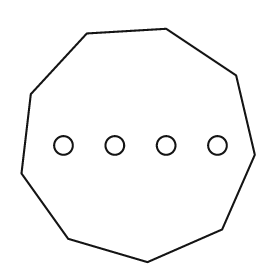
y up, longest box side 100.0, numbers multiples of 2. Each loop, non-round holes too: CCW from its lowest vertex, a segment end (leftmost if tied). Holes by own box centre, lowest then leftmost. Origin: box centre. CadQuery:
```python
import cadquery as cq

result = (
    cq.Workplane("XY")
    .moveTo(4.0, -50.0)
    .lineTo(36.0, -36.0)
    .lineTo(50.0, -4.0)
    .lineTo(42.0, 30.0)
    .lineTo(12.0, 50.0)
    .lineTo(-22.0, 48.0)
    .lineTo(-46.0, 22.0)
    .lineTo(-50.0, -12.0)
    .lineTo(-30.0, -40.0)
    .close()
    .moveTo(-32.0, 0.0)
    .circle(4.0)
    .moveTo(-10.0, 0.0)
    .circle(4.0)
    .moveTo(12.0, 0.0)
    .circle(4.0)
    .moveTo(34.0, 0.0)
    .circle(4.0)
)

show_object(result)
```